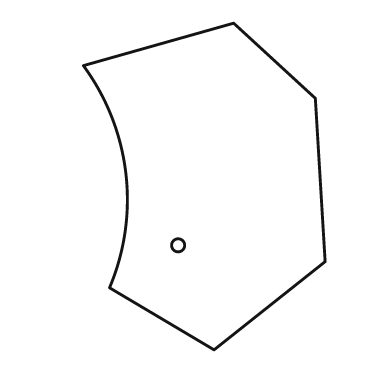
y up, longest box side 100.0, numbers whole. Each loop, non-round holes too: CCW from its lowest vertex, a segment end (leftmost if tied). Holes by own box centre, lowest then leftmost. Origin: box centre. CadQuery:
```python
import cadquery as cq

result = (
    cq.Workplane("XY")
    .moveTo(3.0, -50.0)
    .lineTo(37.0, -23.0)
    .lineTo(34.0, 27.0)
    .lineTo(9.0, 50.0)
    .lineTo(-37.0, 37.0)
    .threePointArc((-24.0, 4.0), (-29.0, -31.0))
    .close()
    .moveTo(-8.0, -18.0)
    .circle(2.0)
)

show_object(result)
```